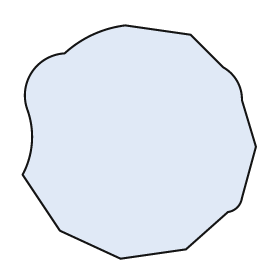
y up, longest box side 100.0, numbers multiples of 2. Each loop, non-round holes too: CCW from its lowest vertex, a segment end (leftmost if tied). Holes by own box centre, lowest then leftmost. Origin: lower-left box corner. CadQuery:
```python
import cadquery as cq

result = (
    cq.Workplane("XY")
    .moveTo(42.0, 0.0)
    .lineTo(70.0, 4.0)
    .lineTo(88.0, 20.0)
    .threePointArc((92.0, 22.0), (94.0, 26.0))
    .lineTo(100.0, 48.0)
    .lineTo(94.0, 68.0)
    .threePointArc((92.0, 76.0), (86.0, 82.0))
    .lineTo(72.0, 96.0)
    .lineTo(44.0, 100.0)
    .threePointArc((30.0, 96.0), (18.0, 88.0))
    .threePointArc((4.0, 80.0), (2.0, 64.0))
    .threePointArc((4.0, 50.0), (0.0, 36.0))
    .lineTo(16.0, 12.0)
    .close()
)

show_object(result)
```